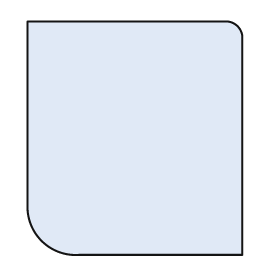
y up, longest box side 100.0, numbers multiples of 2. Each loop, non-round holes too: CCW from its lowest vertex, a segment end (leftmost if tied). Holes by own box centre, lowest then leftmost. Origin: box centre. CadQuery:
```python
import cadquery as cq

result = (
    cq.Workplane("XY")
    .moveTo(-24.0, -50.0)
    .lineTo(46.0, -50.0)
    .lineTo(46.0, 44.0)
    .threePointArc((44.0, 48.0), (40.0, 50.0))
    .lineTo(-46.0, 50.0)
    .lineTo(-46.0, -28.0)
    .threePointArc((-40.0, -44.0), (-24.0, -50.0))
    .close()
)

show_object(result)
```